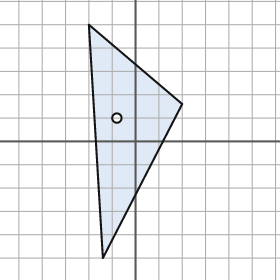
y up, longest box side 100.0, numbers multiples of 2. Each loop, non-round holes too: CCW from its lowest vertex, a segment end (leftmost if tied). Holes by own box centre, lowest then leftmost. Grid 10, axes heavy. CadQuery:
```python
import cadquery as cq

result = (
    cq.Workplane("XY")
    .moveTo(-14.0, -50.0)
    .lineTo(20.0, 16.0)
    .lineTo(-20.0, 50.0)
    .close()
    .moveTo(-8.0, 10.0)
    .circle(2.0)
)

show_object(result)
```